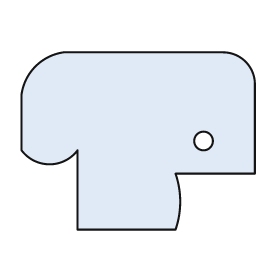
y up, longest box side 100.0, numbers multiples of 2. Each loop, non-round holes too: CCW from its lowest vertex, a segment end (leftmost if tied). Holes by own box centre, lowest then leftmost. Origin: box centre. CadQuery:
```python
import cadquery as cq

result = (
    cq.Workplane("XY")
    .moveTo(-26.0, -38.0)
    .lineTo(16.0, -38.0)
    .threePointArc((18.0, -26.0), (16.0, -14.0))
    .lineTo(50.0, -14.0)
    .lineTo(50.0, 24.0)
    .threePointArc((46.0, 34.0), (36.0, 38.0))
    .lineTo(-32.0, 38.0)
    .threePointArc((-44.0, 32.0), (-50.0, 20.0))
    .lineTo(-50.0, -4.0)
    .threePointArc((-38.0, -10.0), (-26.0, -4.0))
    .close()
    .moveTo(28.0, 0.0)
    .circle(4.0)
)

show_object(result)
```